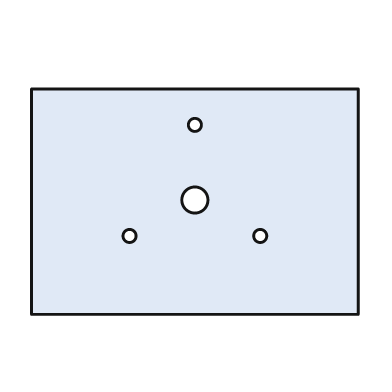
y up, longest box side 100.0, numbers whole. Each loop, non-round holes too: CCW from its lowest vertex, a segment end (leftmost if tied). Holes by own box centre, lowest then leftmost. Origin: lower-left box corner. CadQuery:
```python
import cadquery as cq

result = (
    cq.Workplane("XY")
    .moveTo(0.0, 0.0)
    .lineTo(100.0, 0.0)
    .lineTo(100.0, 69.0)
    .lineTo(0.0, 69.0)
    .close()
    .moveTo(30.0, 24.0)
    .circle(2.0)
    .moveTo(70.0, 24.0)
    .circle(2.0)
    .moveTo(50.0, 35.0)
    .circle(4.0)
    .moveTo(50.0, 58.0)
    .circle(2.0)
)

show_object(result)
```